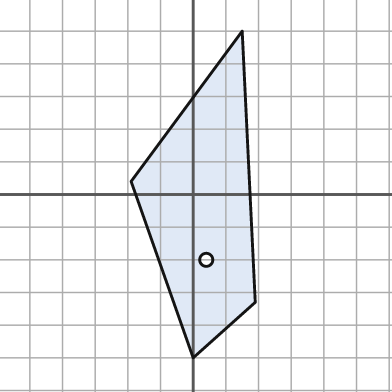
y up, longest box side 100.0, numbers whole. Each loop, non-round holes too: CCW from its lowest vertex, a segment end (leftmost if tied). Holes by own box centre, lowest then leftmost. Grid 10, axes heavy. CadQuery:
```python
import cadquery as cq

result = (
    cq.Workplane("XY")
    .moveTo(0.0, -50.0)
    .lineTo(19.0, -33.0)
    .lineTo(15.0, 50.0)
    .lineTo(-19.0, 4.0)
    .close()
    .moveTo(4.0, -20.0)
    .circle(2.0)
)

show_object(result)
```